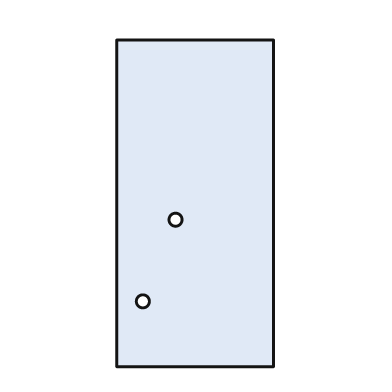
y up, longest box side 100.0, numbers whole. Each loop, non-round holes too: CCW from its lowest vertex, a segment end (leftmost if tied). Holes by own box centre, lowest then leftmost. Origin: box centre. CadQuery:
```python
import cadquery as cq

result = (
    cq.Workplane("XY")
    .moveTo(-24.0, -50.0)
    .lineTo(24.0, -50.0)
    .lineTo(24.0, 50.0)
    .lineTo(-24.0, 50.0)
    .close()
    .moveTo(-16.0, -30.0)
    .circle(2.0)
    .moveTo(-6.0, -5.0)
    .circle(2.0)
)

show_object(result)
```